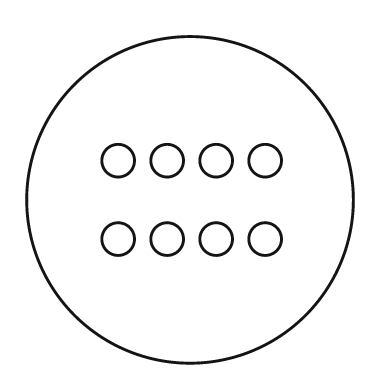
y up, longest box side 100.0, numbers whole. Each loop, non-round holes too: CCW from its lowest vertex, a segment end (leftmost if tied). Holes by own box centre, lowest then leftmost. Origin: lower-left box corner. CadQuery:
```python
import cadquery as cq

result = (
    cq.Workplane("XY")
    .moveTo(50.0, 50.0)
    .circle(50.0)
    .moveTo(28.0, 38.0)
    .circle(5.0)
    .moveTo(43.0, 38.0)
    .circle(5.0)
    .moveTo(58.0, 38.0)
    .circle(5.0)
    .moveTo(73.0, 38.0)
    .circle(5.0)
    .moveTo(28.0, 62.0)
    .circle(5.0)
    .moveTo(43.0, 62.0)
    .circle(5.0)
    .moveTo(58.0, 62.0)
    .circle(5.0)
    .moveTo(73.0, 62.0)
    .circle(5.0)
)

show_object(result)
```